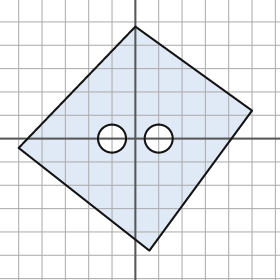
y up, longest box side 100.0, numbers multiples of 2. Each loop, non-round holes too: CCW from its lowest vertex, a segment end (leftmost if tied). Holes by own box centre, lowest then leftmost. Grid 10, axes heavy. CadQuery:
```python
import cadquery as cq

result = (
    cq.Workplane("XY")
    .moveTo(6.0, -48.0)
    .lineTo(50.0, 12.0)
    .lineTo(0.0, 48.0)
    .lineTo(-50.0, -4.0)
    .close()
    .moveTo(-10.0, 0.0)
    .circle(6.0)
    .moveTo(10.0, 0.0)
    .circle(6.0)
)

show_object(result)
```